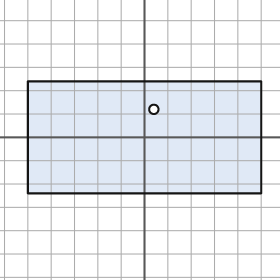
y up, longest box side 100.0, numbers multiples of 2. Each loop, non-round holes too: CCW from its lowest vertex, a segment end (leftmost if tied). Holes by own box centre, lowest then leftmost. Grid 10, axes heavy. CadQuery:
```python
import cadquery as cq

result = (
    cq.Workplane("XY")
    .moveTo(-50.0, -24.0)
    .lineTo(50.0, -24.0)
    .lineTo(50.0, 24.0)
    .lineTo(-50.0, 24.0)
    .close()
    .moveTo(4.0, 12.0)
    .circle(2.0)
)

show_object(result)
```